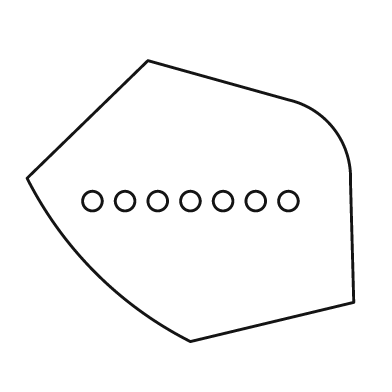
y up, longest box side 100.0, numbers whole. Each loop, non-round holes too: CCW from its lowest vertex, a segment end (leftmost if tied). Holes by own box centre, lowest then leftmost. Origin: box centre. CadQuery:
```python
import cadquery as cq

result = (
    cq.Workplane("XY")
    .moveTo(0.0, -43.0)
    .lineTo(50.0, -31.0)
    .lineTo(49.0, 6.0)
    .threePointArc((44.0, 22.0), (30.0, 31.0))
    .lineTo(-13.0, 43.0)
    .lineTo(-50.0, 7.0)
    .threePointArc((-29.0, -22.0), (0.0, -43.0))
    .close()
    .moveTo(-30.0, 0.0)
    .circle(3.0)
    .moveTo(-20.0, 0.0)
    .circle(3.0)
    .moveTo(-10.0, 0.0)
    .circle(3.0)
    .moveTo(0.0, 0.0)
    .circle(3.0)
    .moveTo(10.0, 0.0)
    .circle(3.0)
    .moveTo(20.0, 0.0)
    .circle(3.0)
    .moveTo(30.0, 0.0)
    .circle(3.0)
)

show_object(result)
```